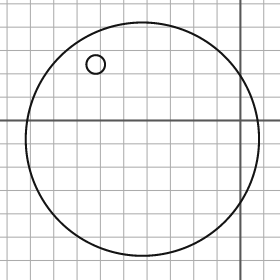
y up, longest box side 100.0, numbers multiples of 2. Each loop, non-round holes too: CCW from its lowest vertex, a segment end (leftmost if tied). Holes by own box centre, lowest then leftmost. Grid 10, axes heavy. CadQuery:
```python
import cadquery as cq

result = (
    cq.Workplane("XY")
    .moveTo(-42.0, -8.0)
    .circle(50.0)
    .moveTo(-62.0, 24.0)
    .circle(4.0)
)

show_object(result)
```